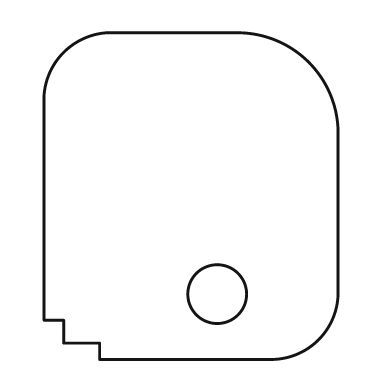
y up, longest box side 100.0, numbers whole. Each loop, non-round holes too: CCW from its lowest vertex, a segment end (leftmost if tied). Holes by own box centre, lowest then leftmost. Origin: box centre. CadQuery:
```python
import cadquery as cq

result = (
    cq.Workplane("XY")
    .moveTo(-28.0, -50.0)
    .lineTo(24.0, -50.0)
    .threePointArc((39.0, -44.0), (45.0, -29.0))
    .lineTo(45.0, 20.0)
    .threePointArc((36.0, 41.0), (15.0, 50.0))
    .lineTo(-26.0, 50.0)
    .threePointArc((-39.0, 44.0), (-45.0, 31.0))
    .lineTo(-45.0, -38.0)
    .lineTo(-39.0, -38.0)
    .lineTo(-39.0, -45.0)
    .lineTo(-28.0, -45.0)
    .close()
    .moveTo(8.0, -30.0)
    .circle(9.0)
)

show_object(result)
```